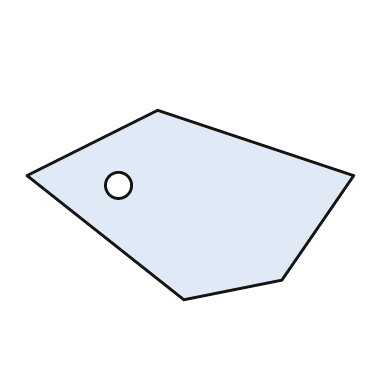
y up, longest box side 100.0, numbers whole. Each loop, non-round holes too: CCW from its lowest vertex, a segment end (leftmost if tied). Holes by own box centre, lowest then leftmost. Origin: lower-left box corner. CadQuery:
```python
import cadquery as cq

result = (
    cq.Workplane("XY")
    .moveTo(48.0, 0.0)
    .lineTo(78.0, 6.0)
    .lineTo(100.0, 38.0)
    .lineTo(40.0, 58.0)
    .lineTo(0.0, 38.0)
    .close()
    .moveTo(28.0, 35.0)
    .circle(4.0)
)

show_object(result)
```